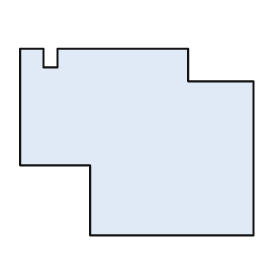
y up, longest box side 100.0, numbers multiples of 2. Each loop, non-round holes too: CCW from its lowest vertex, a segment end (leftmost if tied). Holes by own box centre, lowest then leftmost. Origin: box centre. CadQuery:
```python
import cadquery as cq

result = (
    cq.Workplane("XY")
    .moveTo(-20.0, -40.0)
    .lineTo(50.0, -40.0)
    .lineTo(50.0, 26.0)
    .lineTo(22.0, 26.0)
    .lineTo(22.0, 40.0)
    .lineTo(-34.0, 40.0)
    .lineTo(-34.0, 32.0)
    .lineTo(-40.0, 32.0)
    .lineTo(-40.0, 40.0)
    .lineTo(-50.0, 40.0)
    .lineTo(-50.0, -10.0)
    .lineTo(-20.0, -10.0)
    .close()
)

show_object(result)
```